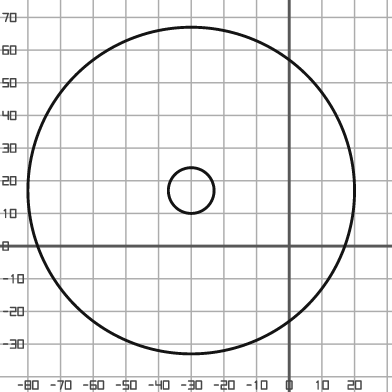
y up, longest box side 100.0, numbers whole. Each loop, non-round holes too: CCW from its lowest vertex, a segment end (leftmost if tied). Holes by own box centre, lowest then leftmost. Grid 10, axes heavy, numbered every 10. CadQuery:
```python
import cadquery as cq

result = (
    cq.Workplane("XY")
    .moveTo(-30.0, 17.0)
    .circle(50.0)
    .moveTo(-30.0, 17.0)
    .circle(7.0)
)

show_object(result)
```